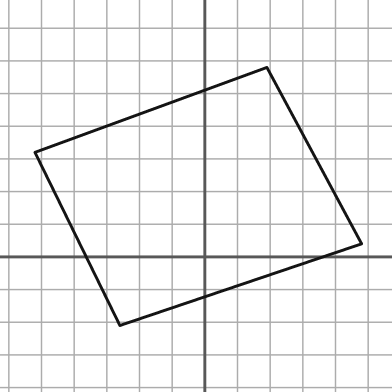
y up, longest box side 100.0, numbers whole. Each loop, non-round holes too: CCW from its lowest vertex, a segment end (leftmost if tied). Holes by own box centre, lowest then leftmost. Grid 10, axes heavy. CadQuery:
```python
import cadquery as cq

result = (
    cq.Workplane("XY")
    .moveTo(-26.0, -21.0)
    .lineTo(48.0, 4.0)
    .lineTo(19.0, 58.0)
    .lineTo(-52.0, 32.0)
    .close()
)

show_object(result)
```